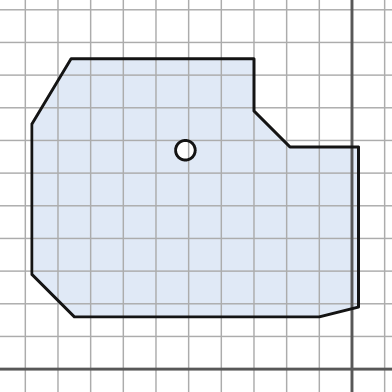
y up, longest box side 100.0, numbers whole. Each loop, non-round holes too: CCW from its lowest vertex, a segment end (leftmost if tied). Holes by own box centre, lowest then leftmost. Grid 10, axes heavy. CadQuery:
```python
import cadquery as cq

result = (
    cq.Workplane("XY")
    .moveTo(-85.0, 16.0)
    .lineTo(-10.0, 16.0)
    .lineTo(2.0, 19.0)
    .lineTo(2.0, 68.0)
    .lineTo(-19.0, 68.0)
    .lineTo(-30.0, 79.0)
    .lineTo(-30.0, 95.0)
    .lineTo(-86.0, 95.0)
    .lineTo(-98.0, 75.0)
    .lineTo(-98.0, 29.0)
    .close()
    .moveTo(-51.0, 67.0)
    .circle(3.0)
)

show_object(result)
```